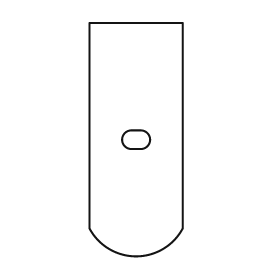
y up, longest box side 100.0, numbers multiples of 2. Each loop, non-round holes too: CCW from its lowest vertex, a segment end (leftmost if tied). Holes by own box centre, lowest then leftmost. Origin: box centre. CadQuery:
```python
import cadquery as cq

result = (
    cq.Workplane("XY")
    .moveTo(-20.0, -38.0)
    .threePointArc((0.0, -50.0), (20.0, -38.0))
    .lineTo(20.0, 50.0)
    .lineTo(-20.0, 50.0)
    .close()
    .moveTo(-2.0, -4.0)
    .lineTo(2.0, -4.0)
    .threePointArc((6.0, 0.0), (2.0, 4.0))
    .lineTo(-2.0, 4.0)
    .threePointArc((-6.0, 0.0), (-2.0, -4.0))
    .close()
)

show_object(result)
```